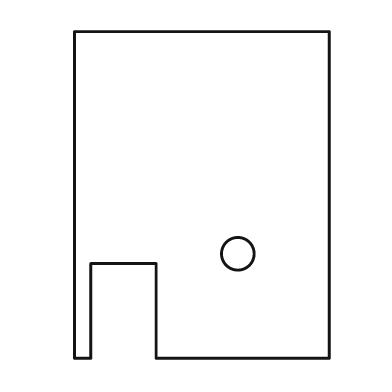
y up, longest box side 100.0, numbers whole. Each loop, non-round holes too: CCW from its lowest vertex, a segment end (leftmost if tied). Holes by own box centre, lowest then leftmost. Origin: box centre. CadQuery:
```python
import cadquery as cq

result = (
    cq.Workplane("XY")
    .moveTo(-39.0, -50.0)
    .lineTo(-34.0, -50.0)
    .lineTo(-34.0, -21.0)
    .lineTo(-14.0, -21.0)
    .lineTo(-14.0, -50.0)
    .lineTo(39.0, -50.0)
    .lineTo(39.0, 50.0)
    .lineTo(-39.0, 50.0)
    .close()
    .moveTo(11.0, -18.0)
    .circle(5.0)
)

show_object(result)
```